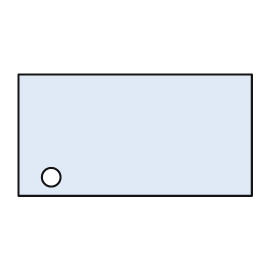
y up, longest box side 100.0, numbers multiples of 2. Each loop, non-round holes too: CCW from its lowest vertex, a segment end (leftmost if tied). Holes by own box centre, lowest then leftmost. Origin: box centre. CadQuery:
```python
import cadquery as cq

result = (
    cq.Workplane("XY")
    .moveTo(-50.0, -26.0)
    .lineTo(50.0, -26.0)
    .lineTo(50.0, 26.0)
    .lineTo(-50.0, 26.0)
    .close()
    .moveTo(-36.0, -18.0)
    .circle(4.0)
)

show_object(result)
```